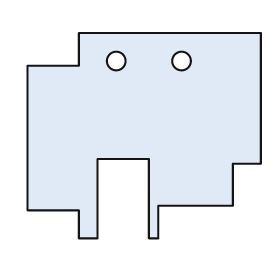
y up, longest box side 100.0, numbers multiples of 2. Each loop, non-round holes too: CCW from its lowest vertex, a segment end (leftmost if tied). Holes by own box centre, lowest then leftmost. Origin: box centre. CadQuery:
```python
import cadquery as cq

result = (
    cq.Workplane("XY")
    .moveTo(-28.0, -44.0)
    .lineTo(-20.0, -44.0)
    .lineTo(-20.0, -10.0)
    .lineTo(2.0, -10.0)
    .lineTo(2.0, -44.0)
    .lineTo(6.0, -44.0)
    .lineTo(6.0, -30.0)
    .lineTo(38.0, -30.0)
    .lineTo(38.0, -12.0)
    .lineTo(50.0, -12.0)
    .lineTo(50.0, 44.0)
    .lineTo(-28.0, 44.0)
    .lineTo(-28.0, 30.0)
    .lineTo(-50.0, 30.0)
    .lineTo(-50.0, -32.0)
    .lineTo(-28.0, -32.0)
    .close()
    .moveTo(-12.0, 32.0)
    .circle(4.0)
    .moveTo(16.0, 32.0)
    .circle(4.0)
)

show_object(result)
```